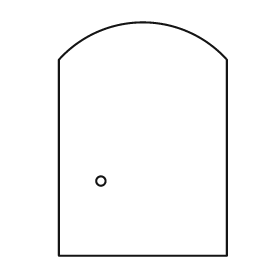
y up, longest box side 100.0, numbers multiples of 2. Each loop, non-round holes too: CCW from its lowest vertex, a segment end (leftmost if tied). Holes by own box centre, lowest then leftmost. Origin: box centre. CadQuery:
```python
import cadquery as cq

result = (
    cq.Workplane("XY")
    .moveTo(-36.0, -50.0)
    .lineTo(36.0, -50.0)
    .lineTo(36.0, 34.0)
    .threePointArc((0.0, 50.0), (-36.0, 34.0))
    .close()
    .moveTo(-18.0, -18.0)
    .circle(2.0)
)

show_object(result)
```